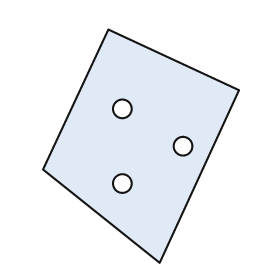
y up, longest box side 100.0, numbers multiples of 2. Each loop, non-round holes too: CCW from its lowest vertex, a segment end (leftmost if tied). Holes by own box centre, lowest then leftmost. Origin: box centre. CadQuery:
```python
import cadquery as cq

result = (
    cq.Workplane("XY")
    .moveTo(8.0, -50.0)
    .lineTo(42.0, 24.0)
    .lineTo(-14.0, 50.0)
    .lineTo(-42.0, -10.0)
    .close()
    .moveTo(-8.0, -16.0)
    .circle(4.0)
    .moveTo(18.0, 0.0)
    .circle(4.0)
    .moveTo(-8.0, 16.0)
    .circle(4.0)
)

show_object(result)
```